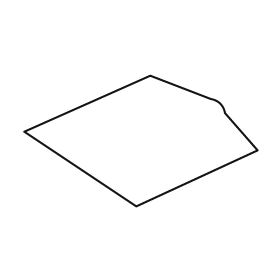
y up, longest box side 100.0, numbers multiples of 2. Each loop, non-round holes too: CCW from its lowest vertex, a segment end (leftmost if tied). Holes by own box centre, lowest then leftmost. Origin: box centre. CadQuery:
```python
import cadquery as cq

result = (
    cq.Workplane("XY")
    .moveTo(-2.0, -28.0)
    .lineTo(50.0, -4.0)
    .lineTo(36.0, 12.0)
    .threePointArc((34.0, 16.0), (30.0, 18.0))
    .lineTo(4.0, 28.0)
    .lineTo(-50.0, 4.0)
    .close()
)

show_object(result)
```